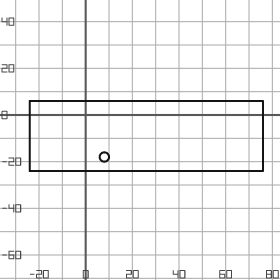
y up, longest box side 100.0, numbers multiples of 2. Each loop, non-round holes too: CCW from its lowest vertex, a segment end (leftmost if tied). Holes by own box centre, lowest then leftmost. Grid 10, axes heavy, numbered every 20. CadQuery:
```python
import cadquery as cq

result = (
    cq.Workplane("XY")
    .moveTo(-24.0, -24.0)
    .lineTo(76.0, -24.0)
    .lineTo(76.0, 6.0)
    .lineTo(-24.0, 6.0)
    .close()
    .moveTo(8.0, -18.0)
    .circle(2.0)
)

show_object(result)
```